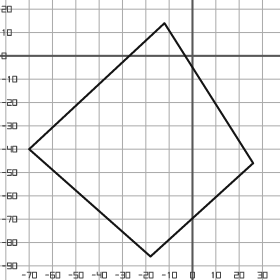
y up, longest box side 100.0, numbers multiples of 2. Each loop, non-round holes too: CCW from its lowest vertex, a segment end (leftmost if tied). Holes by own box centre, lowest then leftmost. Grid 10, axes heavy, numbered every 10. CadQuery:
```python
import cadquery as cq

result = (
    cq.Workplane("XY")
    .moveTo(-18.0, -86.0)
    .lineTo(26.0, -46.0)
    .lineTo(-12.0, 14.0)
    .lineTo(-70.0, -40.0)
    .close()
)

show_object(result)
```